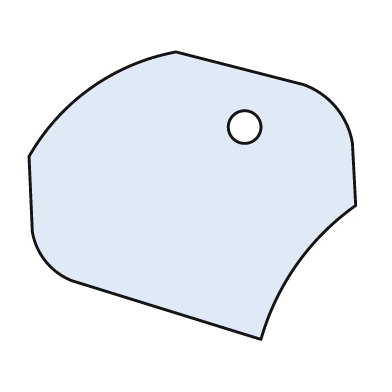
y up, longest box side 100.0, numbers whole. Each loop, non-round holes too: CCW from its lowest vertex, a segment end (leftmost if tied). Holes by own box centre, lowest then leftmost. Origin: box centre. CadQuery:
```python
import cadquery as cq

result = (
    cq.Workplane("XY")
    .moveTo(21.0, -44.0)
    .threePointArc((32.0, -21.0), (50.0, -3.0))
    .lineTo(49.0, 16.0)
    .threePointArc((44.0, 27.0), (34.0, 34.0))
    .lineTo(-5.0, 44.0)
    .threePointArc((-31.0, 33.0), (-50.0, 12.0))
    .lineTo(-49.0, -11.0)
    .threePointArc((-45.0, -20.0), (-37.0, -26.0))
    .close()
    .moveTo(16.0, 21.0)
    .circle(5.0)
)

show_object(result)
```